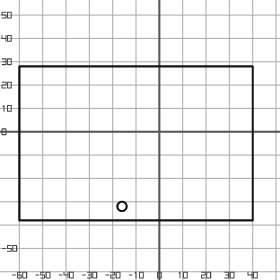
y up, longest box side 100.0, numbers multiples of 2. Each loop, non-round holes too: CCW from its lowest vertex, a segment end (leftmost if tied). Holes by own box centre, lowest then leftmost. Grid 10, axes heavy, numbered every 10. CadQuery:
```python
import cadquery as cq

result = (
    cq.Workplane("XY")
    .moveTo(-60.0, -38.0)
    .lineTo(40.0, -38.0)
    .lineTo(40.0, 28.0)
    .lineTo(-60.0, 28.0)
    .close()
    .moveTo(-16.0, -32.0)
    .circle(2.0)
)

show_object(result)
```